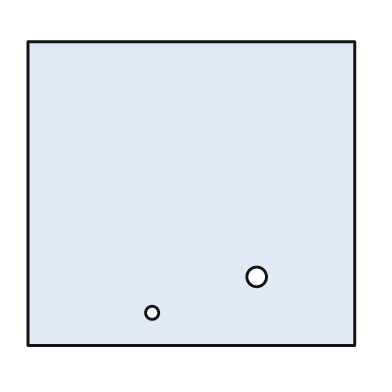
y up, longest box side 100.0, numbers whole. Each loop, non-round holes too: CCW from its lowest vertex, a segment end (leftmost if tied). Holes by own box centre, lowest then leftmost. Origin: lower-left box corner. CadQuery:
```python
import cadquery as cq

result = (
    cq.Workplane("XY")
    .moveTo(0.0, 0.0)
    .lineTo(100.0, 0.0)
    .lineTo(100.0, 93.0)
    .lineTo(0.0, 93.0)
    .close()
    .moveTo(38.0, 10.0)
    .circle(2.0)
    .moveTo(70.0, 21.0)
    .circle(3.0)
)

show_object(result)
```